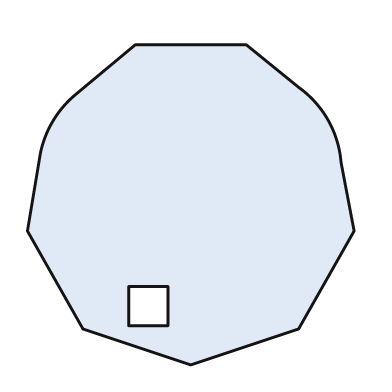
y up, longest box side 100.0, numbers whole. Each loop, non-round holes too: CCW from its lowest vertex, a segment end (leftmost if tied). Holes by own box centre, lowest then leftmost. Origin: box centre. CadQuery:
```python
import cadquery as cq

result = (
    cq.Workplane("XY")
    .moveTo(0.0, -49.0)
    .lineTo(33.0, -38.0)
    .lineTo(50.0, -8.0)
    .lineTo(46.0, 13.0)
    .threePointArc((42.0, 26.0), (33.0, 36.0))
    .lineTo(17.0, 49.0)
    .lineTo(-17.0, 49.0)
    .lineTo(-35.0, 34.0)
    .threePointArc((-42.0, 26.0), (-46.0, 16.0))
    .lineTo(-50.0, -8.0)
    .lineTo(-33.0, -38.0)
    .close()
    .moveTo(-19.0, -37.0)
    .lineTo(-7.0, -37.0)
    .lineTo(-7.0, -25.0)
    .lineTo(-19.0, -25.0)
    .close()
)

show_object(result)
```